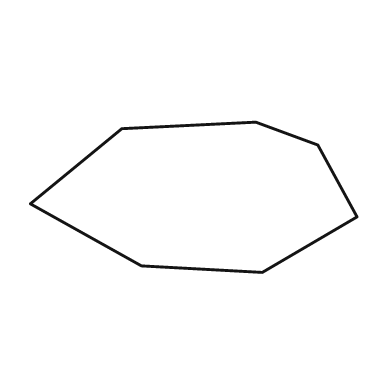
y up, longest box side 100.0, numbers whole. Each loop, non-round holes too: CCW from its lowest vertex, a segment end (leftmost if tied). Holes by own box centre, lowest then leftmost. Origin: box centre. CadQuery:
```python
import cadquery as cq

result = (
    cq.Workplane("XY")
    .moveTo(21.0, -23.0)
    .lineTo(50.0, -6.0)
    .lineTo(38.0, 16.0)
    .lineTo(19.0, 23.0)
    .lineTo(-22.0, 21.0)
    .lineTo(-50.0, -2.0)
    .lineTo(-16.0, -21.0)
    .close()
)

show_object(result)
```